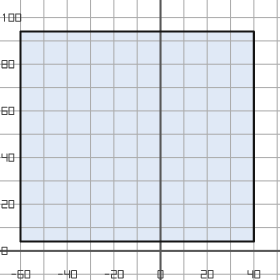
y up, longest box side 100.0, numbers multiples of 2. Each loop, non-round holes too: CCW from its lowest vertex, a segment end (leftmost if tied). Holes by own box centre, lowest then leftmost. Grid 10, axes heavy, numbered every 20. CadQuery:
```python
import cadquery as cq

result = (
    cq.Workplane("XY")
    .moveTo(-60.0, 4.0)
    .lineTo(40.0, 4.0)
    .lineTo(40.0, 94.0)
    .lineTo(-60.0, 94.0)
    .close()
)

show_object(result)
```